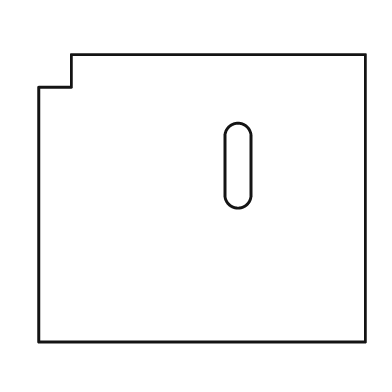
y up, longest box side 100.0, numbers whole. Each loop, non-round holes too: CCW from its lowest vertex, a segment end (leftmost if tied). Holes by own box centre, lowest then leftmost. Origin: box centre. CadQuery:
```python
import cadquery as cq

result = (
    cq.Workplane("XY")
    .moveTo(-50.0, -44.0)
    .lineTo(50.0, -44.0)
    .lineTo(50.0, 44.0)
    .lineTo(-40.0, 44.0)
    .lineTo(-40.0, 34.0)
    .lineTo(-50.0, 34.0)
    .close()
    .moveTo(7.0, 1.0)
    .threePointArc((11.0, -3.0), (15.0, 1.0))
    .lineTo(15.0, 19.0)
    .threePointArc((11.0, 23.0), (7.0, 19.0))
    .close()
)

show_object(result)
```